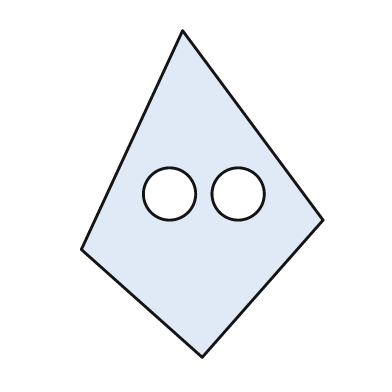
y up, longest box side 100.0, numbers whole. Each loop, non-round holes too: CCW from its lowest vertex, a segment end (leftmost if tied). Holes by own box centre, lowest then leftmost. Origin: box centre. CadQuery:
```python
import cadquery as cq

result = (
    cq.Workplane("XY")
    .moveTo(0.0, -50.0)
    .lineTo(37.0, -8.0)
    .lineTo(-6.0, 50.0)
    .lineTo(-37.0, -17.0)
    .close()
    .moveTo(-10.0, 0.0)
    .circle(8.0)
    .moveTo(11.0, 0.0)
    .circle(8.0)
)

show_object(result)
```